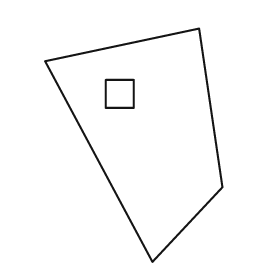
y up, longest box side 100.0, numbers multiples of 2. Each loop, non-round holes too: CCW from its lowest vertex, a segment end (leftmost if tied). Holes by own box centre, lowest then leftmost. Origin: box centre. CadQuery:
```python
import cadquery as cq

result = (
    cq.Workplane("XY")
    .moveTo(8.0, -50.0)
    .lineTo(38.0, -18.0)
    .lineTo(28.0, 50.0)
    .lineTo(-38.0, 36.0)
    .close()
    .moveTo(-12.0, 16.0)
    .lineTo(0.0, 16.0)
    .lineTo(0.0, 28.0)
    .lineTo(-12.0, 28.0)
    .close()
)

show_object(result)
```